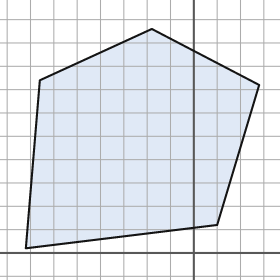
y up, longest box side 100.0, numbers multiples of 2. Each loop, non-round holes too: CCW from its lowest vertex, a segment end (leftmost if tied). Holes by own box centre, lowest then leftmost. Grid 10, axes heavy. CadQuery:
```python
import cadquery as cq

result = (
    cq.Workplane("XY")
    .moveTo(-72.0, 2.0)
    .lineTo(10.0, 12.0)
    .lineTo(28.0, 72.0)
    .lineTo(-18.0, 96.0)
    .lineTo(-66.0, 74.0)
    .close()
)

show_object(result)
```